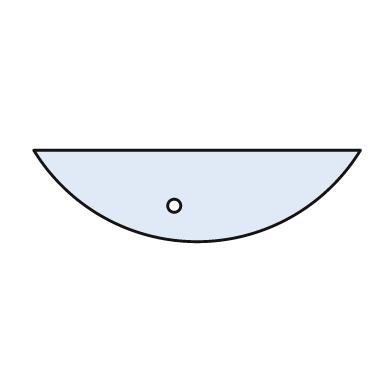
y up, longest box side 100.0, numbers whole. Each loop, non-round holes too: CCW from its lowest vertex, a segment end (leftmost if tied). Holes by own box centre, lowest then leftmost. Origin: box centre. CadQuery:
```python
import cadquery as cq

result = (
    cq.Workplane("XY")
    .moveTo(-50.0, 14.0)
    .threePointArc((0.0, -14.0), (50.0, 14.0))
    .close()
    .moveTo(-7.0, -3.0)
    .circle(2.0)
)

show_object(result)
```